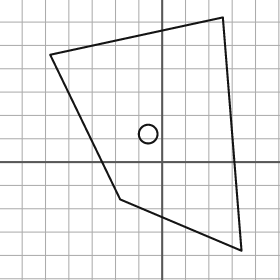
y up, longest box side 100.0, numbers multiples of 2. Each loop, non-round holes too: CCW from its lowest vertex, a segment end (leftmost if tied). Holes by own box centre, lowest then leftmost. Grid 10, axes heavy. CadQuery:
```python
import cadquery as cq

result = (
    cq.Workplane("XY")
    .moveTo(34.0, -38.0)
    .lineTo(26.0, 62.0)
    .lineTo(-48.0, 46.0)
    .lineTo(-18.0, -16.0)
    .close()
    .moveTo(-6.0, 12.0)
    .circle(4.0)
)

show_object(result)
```